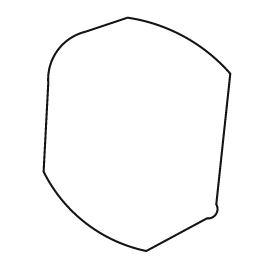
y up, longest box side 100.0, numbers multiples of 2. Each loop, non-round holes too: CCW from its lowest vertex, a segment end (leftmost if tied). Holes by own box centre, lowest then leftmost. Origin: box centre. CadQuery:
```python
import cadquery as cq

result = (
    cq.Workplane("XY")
    .moveTo(4.0, -50.0)
    .lineTo(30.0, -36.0)
    .threePointArc((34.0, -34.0), (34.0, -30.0))
    .lineTo(40.0, 26.0)
    .threePointArc((20.0, 42.0), (-4.0, 50.0))
    .lineTo(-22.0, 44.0)
    .threePointArc((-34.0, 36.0), (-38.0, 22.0))
    .lineTo(-40.0, -16.0)
    .threePointArc((-22.0, -38.0), (4.0, -50.0))
    .close()
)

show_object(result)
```